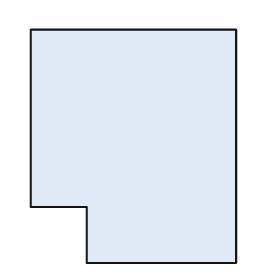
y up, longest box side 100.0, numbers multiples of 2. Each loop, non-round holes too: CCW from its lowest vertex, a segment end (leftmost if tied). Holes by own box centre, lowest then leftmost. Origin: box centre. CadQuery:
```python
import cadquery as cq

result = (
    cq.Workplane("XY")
    .moveTo(-20.0, -50.0)
    .lineTo(44.0, -50.0)
    .lineTo(44.0, 50.0)
    .lineTo(-44.0, 50.0)
    .lineTo(-44.0, -26.0)
    .lineTo(-20.0, -26.0)
    .close()
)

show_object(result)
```